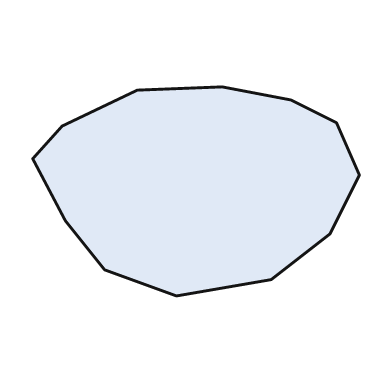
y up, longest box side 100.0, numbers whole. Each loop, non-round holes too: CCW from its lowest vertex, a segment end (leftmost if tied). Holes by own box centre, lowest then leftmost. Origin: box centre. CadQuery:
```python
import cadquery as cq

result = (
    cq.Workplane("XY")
    .moveTo(-6.0, -32.0)
    .lineTo(23.0, -27.0)
    .lineTo(41.0, -13.0)
    .lineTo(50.0, 5.0)
    .lineTo(43.0, 21.0)
    .lineTo(29.0, 28.0)
    .lineTo(8.0, 32.0)
    .lineTo(-18.0, 31.0)
    .lineTo(-41.0, 20.0)
    .lineTo(-50.0, 10.0)
    .lineTo(-40.0, -9.0)
    .lineTo(-28.0, -24.0)
    .close()
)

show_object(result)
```